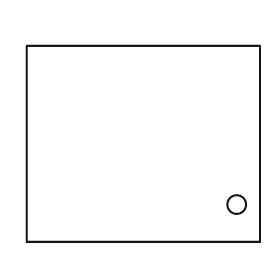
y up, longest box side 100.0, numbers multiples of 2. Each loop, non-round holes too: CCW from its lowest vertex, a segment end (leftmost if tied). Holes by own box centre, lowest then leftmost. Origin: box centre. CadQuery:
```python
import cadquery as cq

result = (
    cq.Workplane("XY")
    .moveTo(-50.0, -42.0)
    .lineTo(50.0, -42.0)
    .lineTo(50.0, 42.0)
    .lineTo(-50.0, 42.0)
    .close()
    .moveTo(40.0, -26.0)
    .circle(4.0)
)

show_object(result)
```